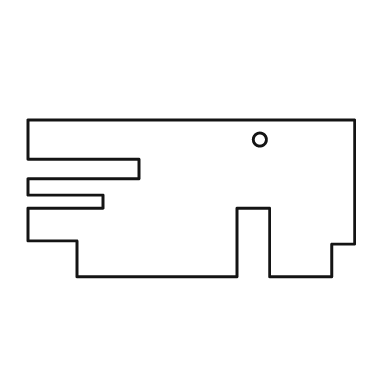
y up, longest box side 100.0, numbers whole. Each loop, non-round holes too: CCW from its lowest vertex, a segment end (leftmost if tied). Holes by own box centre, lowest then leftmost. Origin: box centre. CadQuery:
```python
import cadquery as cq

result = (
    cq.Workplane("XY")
    .moveTo(-35.0, -24.0)
    .lineTo(14.0, -24.0)
    .lineTo(14.0, -3.0)
    .lineTo(24.0, -3.0)
    .lineTo(24.0, -24.0)
    .lineTo(43.0, -24.0)
    .lineTo(43.0, -14.0)
    .lineTo(50.0, -14.0)
    .lineTo(50.0, 24.0)
    .lineTo(-50.0, 24.0)
    .lineTo(-50.0, 12.0)
    .lineTo(-16.0, 12.0)
    .lineTo(-16.0, 6.0)
    .lineTo(-50.0, 6.0)
    .lineTo(-50.0, 1.0)
    .lineTo(-27.0, 1.0)
    .lineTo(-27.0, -3.0)
    .lineTo(-50.0, -3.0)
    .lineTo(-50.0, -13.0)
    .lineTo(-35.0, -13.0)
    .close()
    .moveTo(21.0, 18.0)
    .circle(2.0)
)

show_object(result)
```